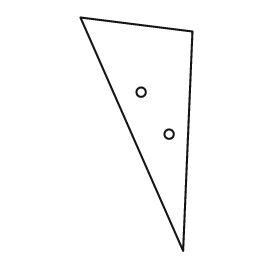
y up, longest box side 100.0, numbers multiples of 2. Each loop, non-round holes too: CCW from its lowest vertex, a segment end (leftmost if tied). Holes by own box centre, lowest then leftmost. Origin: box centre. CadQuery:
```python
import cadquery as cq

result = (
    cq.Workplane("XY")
    .moveTo(20.0, -50.0)
    .lineTo(24.0, 44.0)
    .lineTo(-24.0, 50.0)
    .close()
    .moveTo(14.0, 0.0)
    .circle(2.0)
    .moveTo(2.0, 18.0)
    .circle(2.0)
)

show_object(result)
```